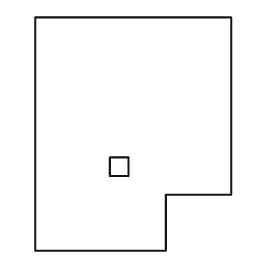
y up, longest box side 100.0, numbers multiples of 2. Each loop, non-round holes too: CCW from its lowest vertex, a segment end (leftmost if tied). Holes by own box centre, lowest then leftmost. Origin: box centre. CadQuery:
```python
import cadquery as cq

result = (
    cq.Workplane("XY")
    .moveTo(-42.0, -50.0)
    .lineTo(14.0, -50.0)
    .lineTo(14.0, -26.0)
    .lineTo(42.0, -26.0)
    .lineTo(42.0, 50.0)
    .lineTo(-42.0, 50.0)
    .close()
    .moveTo(-10.0, -18.0)
    .lineTo(-2.0, -18.0)
    .lineTo(-2.0, -10.0)
    .lineTo(-10.0, -10.0)
    .close()
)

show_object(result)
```